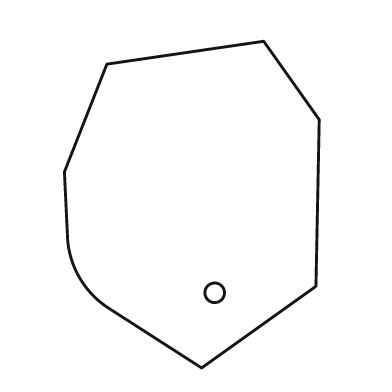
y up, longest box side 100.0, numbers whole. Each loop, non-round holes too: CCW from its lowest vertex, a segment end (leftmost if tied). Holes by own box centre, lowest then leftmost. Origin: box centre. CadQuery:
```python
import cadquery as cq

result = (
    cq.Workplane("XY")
    .moveTo(3.0, -50.0)
    .lineTo(38.0, -25.0)
    .lineTo(39.0, 26.0)
    .lineTo(22.0, 50.0)
    .lineTo(-26.0, 43.0)
    .lineTo(-39.0, 10.0)
    .lineTo(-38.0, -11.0)
    .threePointArc((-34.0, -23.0), (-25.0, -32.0))
    .close()
    .moveTo(7.0, -27.0)
    .circle(3.0)
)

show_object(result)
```